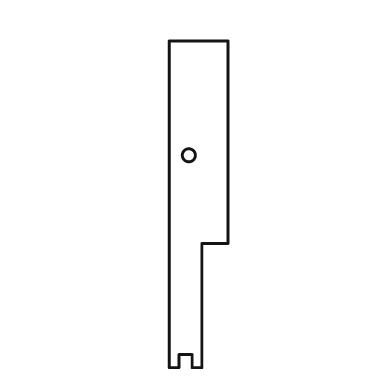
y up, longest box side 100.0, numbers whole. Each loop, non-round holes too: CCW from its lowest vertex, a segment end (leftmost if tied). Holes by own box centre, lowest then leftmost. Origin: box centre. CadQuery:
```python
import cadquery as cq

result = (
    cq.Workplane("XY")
    .moveTo(-9.0, -50.0)
    .lineTo(-6.0, -50.0)
    .lineTo(-6.0, -46.0)
    .lineTo(-2.0, -46.0)
    .lineTo(-2.0, -50.0)
    .lineTo(1.0, -50.0)
    .lineTo(1.0, -12.0)
    .lineTo(9.0, -12.0)
    .lineTo(9.0, 50.0)
    .lineTo(-9.0, 50.0)
    .close()
    .moveTo(-3.0, 15.0)
    .circle(2.0)
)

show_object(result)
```